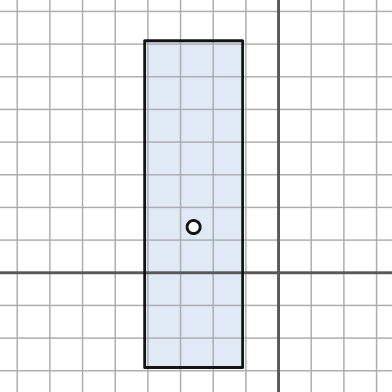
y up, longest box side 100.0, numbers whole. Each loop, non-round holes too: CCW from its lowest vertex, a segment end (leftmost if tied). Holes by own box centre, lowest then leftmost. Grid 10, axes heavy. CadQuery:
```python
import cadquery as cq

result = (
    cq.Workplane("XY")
    .moveTo(-41.0, -29.0)
    .lineTo(-11.0, -29.0)
    .lineTo(-11.0, 71.0)
    .lineTo(-41.0, 71.0)
    .close()
    .moveTo(-26.0, 14.0)
    .circle(2.0)
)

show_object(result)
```